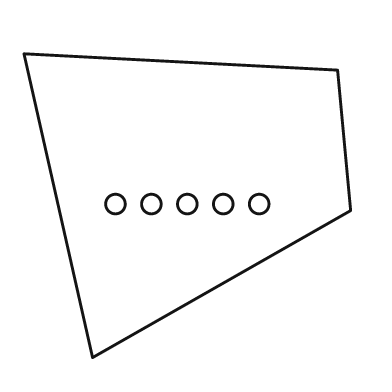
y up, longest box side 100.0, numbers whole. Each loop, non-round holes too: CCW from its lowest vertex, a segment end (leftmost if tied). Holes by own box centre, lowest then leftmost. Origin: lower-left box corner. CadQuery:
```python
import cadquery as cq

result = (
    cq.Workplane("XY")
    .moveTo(21.0, 0.0)
    .lineTo(100.0, 45.0)
    .lineTo(96.0, 88.0)
    .lineTo(0.0, 93.0)
    .close()
    .moveTo(28.0, 47.0)
    .circle(3.0)
    .moveTo(39.0, 47.0)
    .circle(3.0)
    .moveTo(50.0, 47.0)
    .circle(3.0)
    .moveTo(61.0, 47.0)
    .circle(3.0)
    .moveTo(72.0, 47.0)
    .circle(3.0)
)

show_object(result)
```